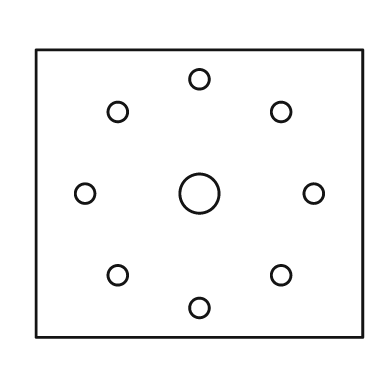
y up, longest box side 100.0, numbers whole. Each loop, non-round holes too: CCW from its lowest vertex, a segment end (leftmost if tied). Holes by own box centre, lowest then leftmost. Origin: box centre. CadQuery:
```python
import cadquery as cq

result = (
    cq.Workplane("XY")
    .moveTo(-50.0, -44.0)
    .lineTo(50.0, -44.0)
    .lineTo(50.0, 44.0)
    .lineTo(-50.0, 44.0)
    .close()
    .moveTo(0.0, -35.0)
    .circle(3.0)
    .moveTo(-25.0, -25.0)
    .circle(3.0)
    .moveTo(25.0, -25.0)
    .circle(3.0)
    .moveTo(-35.0, 0.0)
    .circle(3.0)
    .moveTo(0.0, 0.0)
    .circle(6.0)
    .moveTo(35.0, 0.0)
    .circle(3.0)
    .moveTo(-25.0, 25.0)
    .circle(3.0)
    .moveTo(25.0, 25.0)
    .circle(3.0)
    .moveTo(0.0, 35.0)
    .circle(3.0)
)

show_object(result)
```